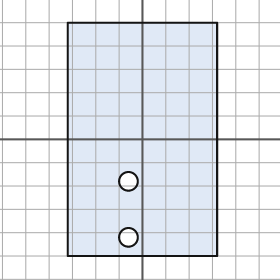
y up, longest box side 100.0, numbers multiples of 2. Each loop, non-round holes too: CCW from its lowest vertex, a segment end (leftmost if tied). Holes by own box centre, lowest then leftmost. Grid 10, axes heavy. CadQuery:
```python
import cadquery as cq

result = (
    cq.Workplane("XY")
    .moveTo(-32.0, -50.0)
    .lineTo(32.0, -50.0)
    .lineTo(32.0, 50.0)
    .lineTo(-32.0, 50.0)
    .close()
    .moveTo(-6.0, -42.0)
    .circle(4.0)
    .moveTo(-6.0, -18.0)
    .circle(4.0)
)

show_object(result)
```